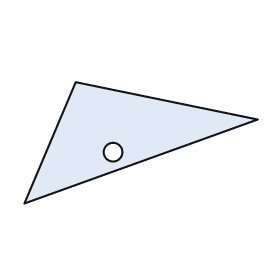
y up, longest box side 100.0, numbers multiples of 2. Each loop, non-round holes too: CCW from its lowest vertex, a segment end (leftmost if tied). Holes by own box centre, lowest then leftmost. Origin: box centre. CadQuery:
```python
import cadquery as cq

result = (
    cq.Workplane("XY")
    .moveTo(-50.0, -26.0)
    .lineTo(50.0, 10.0)
    .lineTo(-28.0, 26.0)
    .close()
    .moveTo(-12.0, -4.0)
    .circle(4.0)
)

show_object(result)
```